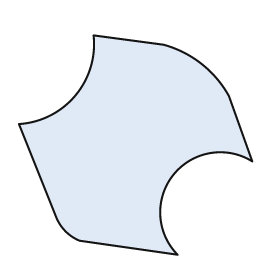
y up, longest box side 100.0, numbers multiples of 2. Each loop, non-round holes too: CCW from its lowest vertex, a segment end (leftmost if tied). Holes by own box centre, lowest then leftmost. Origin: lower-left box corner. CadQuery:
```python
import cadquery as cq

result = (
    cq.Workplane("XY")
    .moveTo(68.0, 0.0)
    .threePointArc((66.0, 34.0), (100.0, 40.0))
    .lineTo(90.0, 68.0)
    .threePointArc((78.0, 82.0), (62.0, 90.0))
    .lineTo(32.0, 94.0)
    .threePointArc((24.0, 68.0), (0.0, 56.0))
    .lineTo(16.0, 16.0)
    .threePointArc((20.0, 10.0), (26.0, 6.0))
    .close()
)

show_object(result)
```